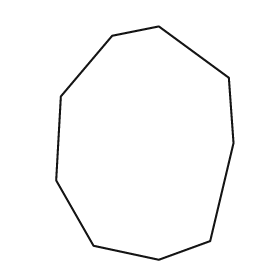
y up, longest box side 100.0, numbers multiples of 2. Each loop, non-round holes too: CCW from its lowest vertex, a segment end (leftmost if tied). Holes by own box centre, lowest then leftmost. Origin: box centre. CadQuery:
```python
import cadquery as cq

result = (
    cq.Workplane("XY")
    .moveTo(6.0, -50.0)
    .lineTo(28.0, -42.0)
    .lineTo(38.0, 0.0)
    .lineTo(36.0, 28.0)
    .lineTo(6.0, 50.0)
    .lineTo(-14.0, 46.0)
    .lineTo(-36.0, 20.0)
    .lineTo(-38.0, -16.0)
    .lineTo(-22.0, -44.0)
    .close()
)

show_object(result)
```